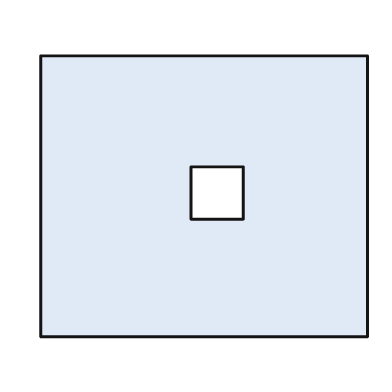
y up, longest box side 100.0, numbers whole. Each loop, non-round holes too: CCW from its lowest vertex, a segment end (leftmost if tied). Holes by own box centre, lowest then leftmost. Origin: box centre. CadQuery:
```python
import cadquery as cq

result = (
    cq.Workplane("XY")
    .moveTo(-50.0, -43.0)
    .lineTo(50.0, -43.0)
    .lineTo(50.0, 43.0)
    .lineTo(-50.0, 43.0)
    .close()
    .moveTo(-4.0, -7.0)
    .lineTo(12.0, -7.0)
    .lineTo(12.0, 9.0)
    .lineTo(-4.0, 9.0)
    .close()
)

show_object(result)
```